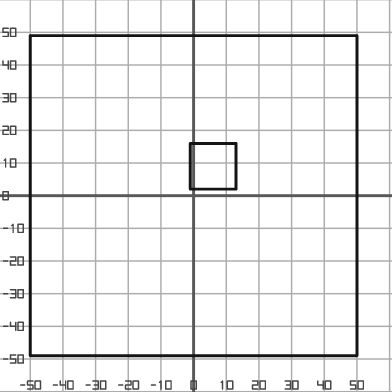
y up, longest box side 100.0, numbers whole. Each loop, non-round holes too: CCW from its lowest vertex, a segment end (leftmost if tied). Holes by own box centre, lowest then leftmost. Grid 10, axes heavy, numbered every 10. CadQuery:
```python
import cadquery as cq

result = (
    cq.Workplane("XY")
    .moveTo(-50.0, -49.0)
    .lineTo(50.0, -49.0)
    .lineTo(50.0, 49.0)
    .lineTo(-50.0, 49.0)
    .close()
    .moveTo(-1.0, 2.0)
    .lineTo(13.0, 2.0)
    .lineTo(13.0, 16.0)
    .lineTo(-1.0, 16.0)
    .close()
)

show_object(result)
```